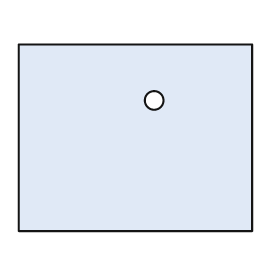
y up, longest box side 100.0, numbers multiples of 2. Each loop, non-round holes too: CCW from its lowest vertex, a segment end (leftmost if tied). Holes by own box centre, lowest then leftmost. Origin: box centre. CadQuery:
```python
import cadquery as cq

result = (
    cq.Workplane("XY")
    .moveTo(-50.0, -40.0)
    .lineTo(50.0, -40.0)
    .lineTo(50.0, 40.0)
    .lineTo(-50.0, 40.0)
    .close()
    .moveTo(8.0, 16.0)
    .circle(4.0)
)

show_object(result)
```